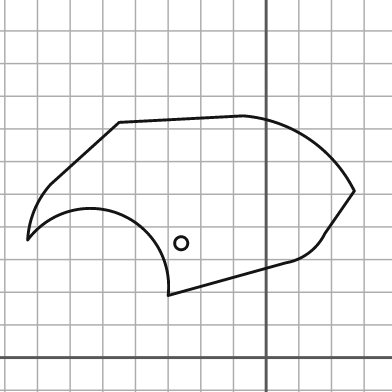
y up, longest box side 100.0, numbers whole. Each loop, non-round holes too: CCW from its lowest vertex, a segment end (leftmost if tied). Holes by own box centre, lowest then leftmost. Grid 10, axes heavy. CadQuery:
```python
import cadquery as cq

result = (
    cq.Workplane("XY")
    .moveTo(-30.0, 19.0)
    .lineTo(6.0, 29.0)
    .threePointArc((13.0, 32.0), (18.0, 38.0))
    .lineTo(27.0, 51.0)
    .threePointArc((13.0, 67.0), (-7.0, 74.0))
    .lineTo(-45.0, 72.0)
    .lineTo(-66.0, 53.0)
    .threePointArc((-71.0, 45.0), (-73.0, 36.0))
    .threePointArc((-45.0, 44.0), (-30.0, 19.0))
    .close()
    .moveTo(-26.0, 35.0)
    .circle(2.0)
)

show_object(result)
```